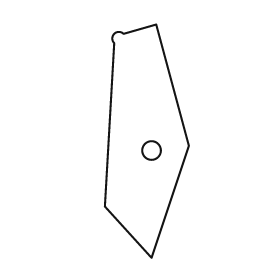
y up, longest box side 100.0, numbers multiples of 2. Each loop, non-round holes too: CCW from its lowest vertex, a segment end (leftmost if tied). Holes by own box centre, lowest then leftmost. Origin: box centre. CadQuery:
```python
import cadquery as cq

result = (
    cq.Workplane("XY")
    .moveTo(2.0, -50.0)
    .lineTo(18.0, -2.0)
    .lineTo(4.0, 50.0)
    .lineTo(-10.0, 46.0)
    .threePointArc((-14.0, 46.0), (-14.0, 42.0))
    .lineTo(-18.0, -28.0)
    .close()
    .moveTo(2.0, -4.0)
    .circle(4.0)
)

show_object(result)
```